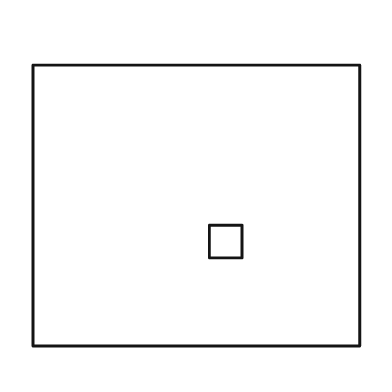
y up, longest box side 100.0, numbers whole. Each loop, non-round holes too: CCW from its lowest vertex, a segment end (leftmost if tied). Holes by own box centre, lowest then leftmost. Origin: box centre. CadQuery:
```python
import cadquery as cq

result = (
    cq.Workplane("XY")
    .moveTo(-50.0, -43.0)
    .lineTo(50.0, -43.0)
    .lineTo(50.0, 43.0)
    .lineTo(-50.0, 43.0)
    .close()
    .moveTo(4.0, -16.0)
    .lineTo(14.0, -16.0)
    .lineTo(14.0, -6.0)
    .lineTo(4.0, -6.0)
    .close()
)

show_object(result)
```